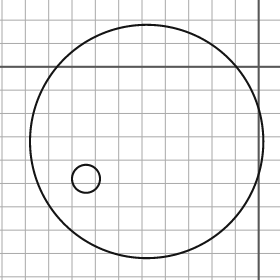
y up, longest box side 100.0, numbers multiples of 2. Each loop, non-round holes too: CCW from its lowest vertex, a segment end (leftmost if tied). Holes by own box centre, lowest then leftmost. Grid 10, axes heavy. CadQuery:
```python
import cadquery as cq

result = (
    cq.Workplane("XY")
    .moveTo(-48.0, -32.0)
    .circle(50.0)
    .moveTo(-74.0, -48.0)
    .circle(6.0)
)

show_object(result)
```